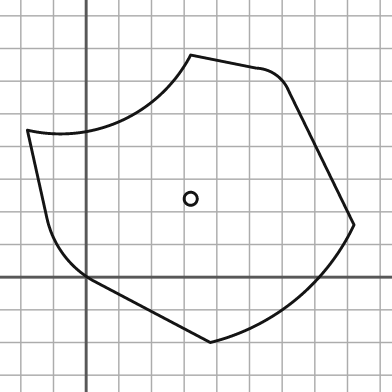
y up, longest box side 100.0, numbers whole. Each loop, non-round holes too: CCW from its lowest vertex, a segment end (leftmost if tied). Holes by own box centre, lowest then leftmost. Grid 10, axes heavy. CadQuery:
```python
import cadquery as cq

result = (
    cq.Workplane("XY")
    .moveTo(38.0, -20.0)
    .threePointArc((64.0, -7.0), (82.0, 16.0))
    .lineTo(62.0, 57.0)
    .threePointArc((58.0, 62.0), (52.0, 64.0))
    .lineTo(32.0, 68.0)
    .threePointArc((11.0, 48.0), (-18.0, 45.0))
    .lineTo(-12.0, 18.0)
    .threePointArc((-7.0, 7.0), (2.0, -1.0))
    .close()
    .moveTo(32.0, 24.0)
    .circle(2.0)
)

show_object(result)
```